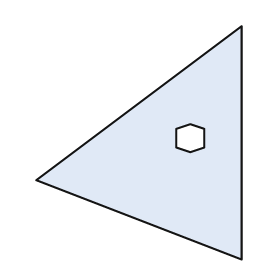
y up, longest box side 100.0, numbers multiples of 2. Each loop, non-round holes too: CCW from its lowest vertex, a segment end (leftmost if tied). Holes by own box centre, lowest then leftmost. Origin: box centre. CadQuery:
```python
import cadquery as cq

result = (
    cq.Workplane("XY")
    .moveTo(44.0, -50.0)
    .lineTo(44.0, 50.0)
    .lineTo(-44.0, -16.0)
    .close()
    .moveTo(22.0, -4.0)
    .lineTo(28.0, -2.0)
    .lineTo(28.0, 6.0)
    .lineTo(22.0, 8.0)
    .lineTo(16.0, 6.0)
    .lineTo(16.0, -2.0)
    .close()
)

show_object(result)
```